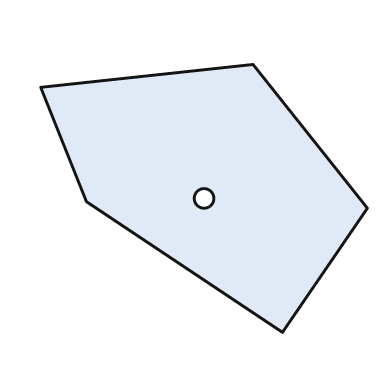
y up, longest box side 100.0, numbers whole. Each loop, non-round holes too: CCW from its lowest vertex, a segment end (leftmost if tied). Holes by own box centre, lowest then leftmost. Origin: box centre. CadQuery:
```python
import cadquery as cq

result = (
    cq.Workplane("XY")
    .moveTo(24.0, -41.0)
    .lineTo(50.0, -3.0)
    .lineTo(15.0, 41.0)
    .lineTo(-50.0, 34.0)
    .lineTo(-36.0, -1.0)
    .close()
    .moveTo(0.0, 0.0)
    .circle(3.0)
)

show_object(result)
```